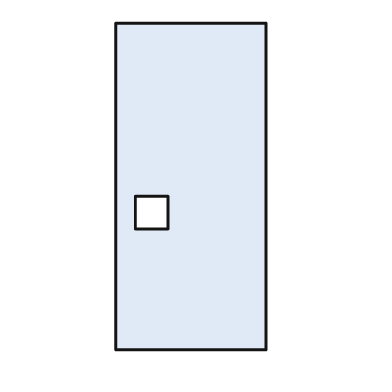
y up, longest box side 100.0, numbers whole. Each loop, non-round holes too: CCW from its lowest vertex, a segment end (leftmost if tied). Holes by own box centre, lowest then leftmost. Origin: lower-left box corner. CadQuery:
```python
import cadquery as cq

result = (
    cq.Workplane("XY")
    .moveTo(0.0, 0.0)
    .lineTo(46.0, 0.0)
    .lineTo(46.0, 100.0)
    .lineTo(0.0, 100.0)
    .close()
    .moveTo(6.0, 37.0)
    .lineTo(16.0, 37.0)
    .lineTo(16.0, 47.0)
    .lineTo(6.0, 47.0)
    .close()
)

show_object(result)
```